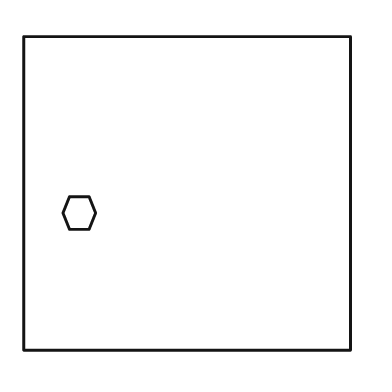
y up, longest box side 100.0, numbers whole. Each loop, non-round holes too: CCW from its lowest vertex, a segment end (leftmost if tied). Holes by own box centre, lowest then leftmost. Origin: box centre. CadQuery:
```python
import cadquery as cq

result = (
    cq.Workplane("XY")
    .moveTo(-50.0, -48.0)
    .lineTo(50.0, -48.0)
    .lineTo(50.0, 48.0)
    .lineTo(-50.0, 48.0)
    .close()
    .moveTo(-36.0, -11.0)
    .lineTo(-30.0, -11.0)
    .lineTo(-28.0, -6.0)
    .lineTo(-30.0, -1.0)
    .lineTo(-36.0, -1.0)
    .lineTo(-38.0, -6.0)
    .close()
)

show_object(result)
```